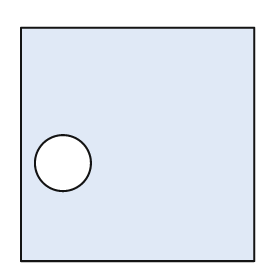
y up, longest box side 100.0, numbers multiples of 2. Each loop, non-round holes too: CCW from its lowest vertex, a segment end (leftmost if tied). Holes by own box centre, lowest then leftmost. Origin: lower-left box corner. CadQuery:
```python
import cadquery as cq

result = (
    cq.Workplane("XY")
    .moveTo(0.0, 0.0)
    .lineTo(100.0, 0.0)
    .lineTo(100.0, 100.0)
    .lineTo(0.0, 100.0)
    .close()
    .moveTo(18.0, 42.0)
    .circle(12.0)
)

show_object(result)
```